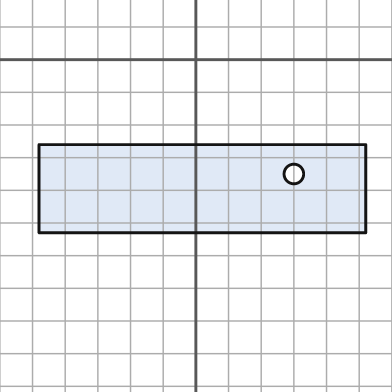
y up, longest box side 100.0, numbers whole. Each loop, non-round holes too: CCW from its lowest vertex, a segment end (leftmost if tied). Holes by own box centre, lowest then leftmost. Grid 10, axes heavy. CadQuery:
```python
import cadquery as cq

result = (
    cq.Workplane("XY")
    .moveTo(-48.0, -53.0)
    .lineTo(52.0, -53.0)
    .lineTo(52.0, -26.0)
    .lineTo(-48.0, -26.0)
    .close()
    .moveTo(30.0, -35.0)
    .circle(3.0)
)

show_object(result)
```